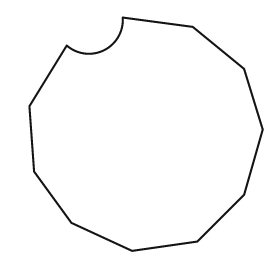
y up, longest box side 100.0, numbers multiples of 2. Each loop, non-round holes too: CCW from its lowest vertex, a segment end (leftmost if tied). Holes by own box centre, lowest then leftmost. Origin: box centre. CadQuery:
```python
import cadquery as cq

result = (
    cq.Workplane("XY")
    .moveTo(-6.0, -50.0)
    .lineTo(22.0, -46.0)
    .lineTo(42.0, -26.0)
    .lineTo(50.0, 2.0)
    .lineTo(42.0, 28.0)
    .lineTo(20.0, 46.0)
    .lineTo(-10.0, 50.0)
    .threePointArc((-18.0, 36.0), (-34.0, 38.0))
    .lineTo(-50.0, 12.0)
    .lineTo(-48.0, -16.0)
    .lineTo(-32.0, -38.0)
    .close()
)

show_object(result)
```